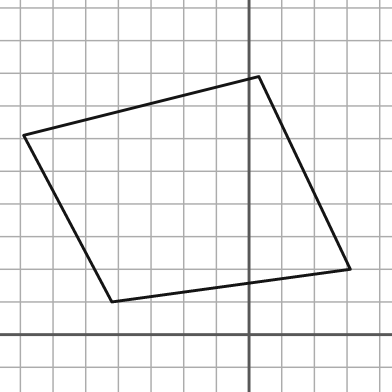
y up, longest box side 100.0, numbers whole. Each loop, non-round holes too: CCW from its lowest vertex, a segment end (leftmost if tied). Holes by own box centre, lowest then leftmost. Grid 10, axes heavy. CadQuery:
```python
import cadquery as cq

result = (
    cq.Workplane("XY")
    .moveTo(-42.0, 10.0)
    .lineTo(31.0, 20.0)
    .lineTo(3.0, 79.0)
    .lineTo(-69.0, 61.0)
    .close()
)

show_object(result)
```